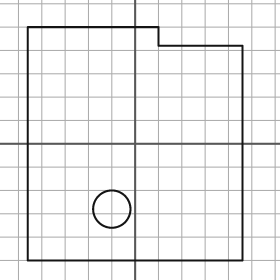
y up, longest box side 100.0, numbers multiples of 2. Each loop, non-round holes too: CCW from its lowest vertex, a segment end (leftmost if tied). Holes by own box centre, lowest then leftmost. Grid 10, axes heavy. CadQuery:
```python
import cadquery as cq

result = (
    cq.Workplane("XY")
    .moveTo(-46.0, -50.0)
    .lineTo(46.0, -50.0)
    .lineTo(46.0, 42.0)
    .lineTo(10.0, 42.0)
    .lineTo(10.0, 50.0)
    .lineTo(-46.0, 50.0)
    .close()
    .moveTo(-10.0, -28.0)
    .circle(8.0)
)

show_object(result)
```